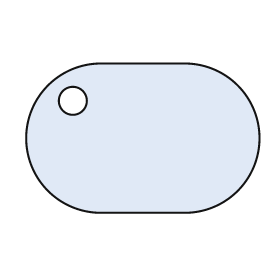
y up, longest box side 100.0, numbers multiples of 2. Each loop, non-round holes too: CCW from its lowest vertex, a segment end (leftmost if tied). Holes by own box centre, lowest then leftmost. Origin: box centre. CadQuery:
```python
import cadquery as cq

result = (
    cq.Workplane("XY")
    .moveTo(-18.0, -32.0)
    .lineTo(18.0, -32.0)
    .threePointArc((50.0, 0.0), (18.0, 32.0))
    .lineTo(-18.0, 32.0)
    .threePointArc((-50.0, 0.0), (-18.0, -32.0))
    .close()
    .moveTo(-30.0, 16.0)
    .circle(6.0)
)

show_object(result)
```